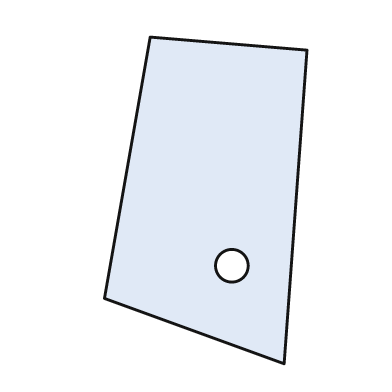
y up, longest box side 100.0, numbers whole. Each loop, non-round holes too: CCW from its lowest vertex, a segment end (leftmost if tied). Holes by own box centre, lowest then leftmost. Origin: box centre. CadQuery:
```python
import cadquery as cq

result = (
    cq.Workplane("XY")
    .moveTo(24.0, -50.0)
    .lineTo(31.0, 46.0)
    .lineTo(-17.0, 50.0)
    .lineTo(-31.0, -30.0)
    .close()
    .moveTo(8.0, -20.0)
    .circle(5.0)
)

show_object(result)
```